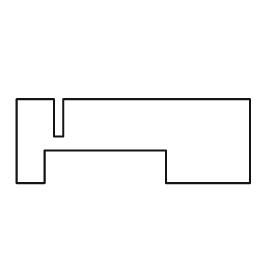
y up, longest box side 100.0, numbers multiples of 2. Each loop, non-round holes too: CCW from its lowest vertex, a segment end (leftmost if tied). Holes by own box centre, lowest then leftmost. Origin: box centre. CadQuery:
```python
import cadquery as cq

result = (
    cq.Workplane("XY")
    .moveTo(-50.0, -18.0)
    .lineTo(-38.0, -18.0)
    .lineTo(-38.0, -4.0)
    .lineTo(14.0, -4.0)
    .lineTo(14.0, -18.0)
    .lineTo(50.0, -18.0)
    .lineTo(50.0, 18.0)
    .lineTo(-30.0, 18.0)
    .lineTo(-30.0, 2.0)
    .lineTo(-34.0, 2.0)
    .lineTo(-34.0, 18.0)
    .lineTo(-50.0, 18.0)
    .close()
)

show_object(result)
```